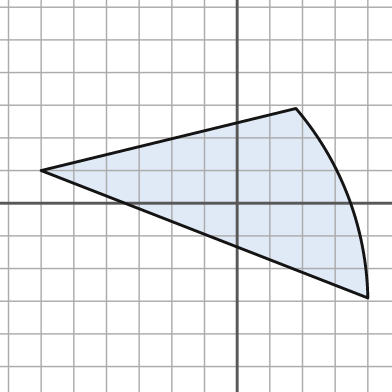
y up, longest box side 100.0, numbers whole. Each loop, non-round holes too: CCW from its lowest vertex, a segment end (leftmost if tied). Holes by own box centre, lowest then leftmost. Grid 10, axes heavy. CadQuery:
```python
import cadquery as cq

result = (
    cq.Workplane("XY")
    .moveTo(40.0, -29.0)
    .threePointArc((34.0, 2.0), (18.0, 29.0))
    .lineTo(-60.0, 10.0)
    .close()
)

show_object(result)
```